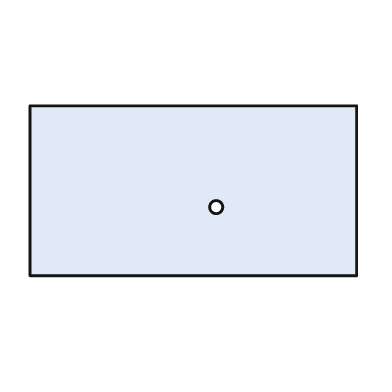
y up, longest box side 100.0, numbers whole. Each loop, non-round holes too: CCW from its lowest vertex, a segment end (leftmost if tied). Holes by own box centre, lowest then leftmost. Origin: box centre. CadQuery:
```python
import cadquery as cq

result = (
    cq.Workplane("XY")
    .moveTo(-50.0, -26.0)
    .lineTo(50.0, -26.0)
    .lineTo(50.0, 26.0)
    .lineTo(-50.0, 26.0)
    .close()
    .moveTo(7.0, -5.0)
    .circle(2.0)
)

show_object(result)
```